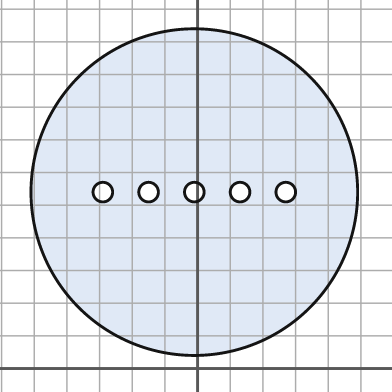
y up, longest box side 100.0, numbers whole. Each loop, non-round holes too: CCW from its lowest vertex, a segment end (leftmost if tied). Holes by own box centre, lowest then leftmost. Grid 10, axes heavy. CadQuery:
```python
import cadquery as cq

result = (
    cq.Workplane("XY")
    .moveTo(-1.0, 54.0)
    .circle(50.0)
    .moveTo(-29.0, 54.0)
    .circle(3.0)
    .moveTo(-15.0, 54.0)
    .circle(3.0)
    .moveTo(-1.0, 54.0)
    .circle(3.0)
    .moveTo(13.0, 54.0)
    .circle(3.0)
    .moveTo(27.0, 54.0)
    .circle(3.0)
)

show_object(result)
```